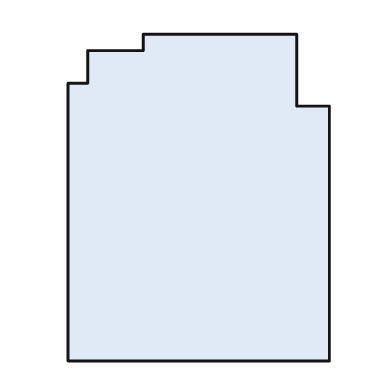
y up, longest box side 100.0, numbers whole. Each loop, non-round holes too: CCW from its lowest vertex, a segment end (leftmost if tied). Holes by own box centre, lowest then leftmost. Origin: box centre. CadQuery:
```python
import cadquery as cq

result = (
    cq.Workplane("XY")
    .moveTo(-40.0, -50.0)
    .lineTo(40.0, -50.0)
    .lineTo(40.0, 28.0)
    .lineTo(30.0, 28.0)
    .lineTo(30.0, 50.0)
    .lineTo(-17.0, 50.0)
    .lineTo(-17.0, 45.0)
    .lineTo(-34.0, 45.0)
    .lineTo(-34.0, 35.0)
    .lineTo(-40.0, 35.0)
    .close()
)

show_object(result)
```